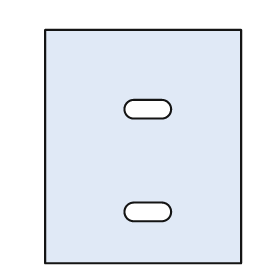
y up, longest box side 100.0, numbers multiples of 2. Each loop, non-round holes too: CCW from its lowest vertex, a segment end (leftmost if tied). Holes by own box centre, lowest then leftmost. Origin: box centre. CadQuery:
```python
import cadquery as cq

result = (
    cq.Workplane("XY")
    .moveTo(-42.0, -50.0)
    .lineTo(42.0, -50.0)
    .lineTo(42.0, 50.0)
    .lineTo(-42.0, 50.0)
    .close()
    .moveTo(-4.0, -32.0)
    .lineTo(8.0, -32.0)
    .threePointArc((12.0, -28.0), (8.0, -24.0))
    .lineTo(-4.0, -24.0)
    .threePointArc((-8.0, -28.0), (-4.0, -32.0))
    .close()
    .moveTo(-4.0, 12.0)
    .lineTo(8.0, 12.0)
    .threePointArc((12.0, 16.0), (8.0, 20.0))
    .lineTo(-4.0, 20.0)
    .threePointArc((-8.0, 16.0), (-4.0, 12.0))
    .close()
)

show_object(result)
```